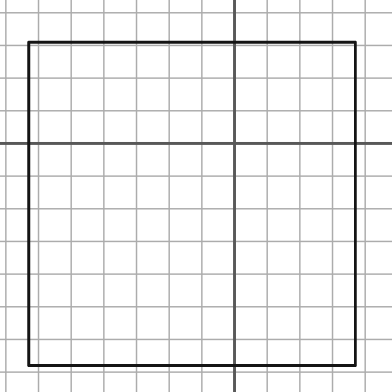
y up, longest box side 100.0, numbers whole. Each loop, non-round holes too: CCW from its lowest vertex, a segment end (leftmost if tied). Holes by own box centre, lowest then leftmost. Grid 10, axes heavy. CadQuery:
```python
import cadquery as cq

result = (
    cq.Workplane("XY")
    .moveTo(-63.0, -68.0)
    .lineTo(37.0, -68.0)
    .lineTo(37.0, 31.0)
    .lineTo(-63.0, 31.0)
    .close()
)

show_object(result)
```